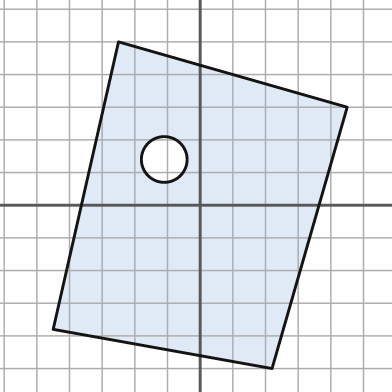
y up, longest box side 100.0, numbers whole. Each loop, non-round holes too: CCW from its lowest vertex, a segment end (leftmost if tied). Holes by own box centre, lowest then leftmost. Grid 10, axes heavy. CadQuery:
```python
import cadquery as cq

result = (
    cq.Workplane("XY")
    .moveTo(22.0, -50.0)
    .lineTo(45.0, 30.0)
    .lineTo(-25.0, 50.0)
    .lineTo(-45.0, -38.0)
    .close()
    .moveTo(-11.0, 14.0)
    .circle(7.0)
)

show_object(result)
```